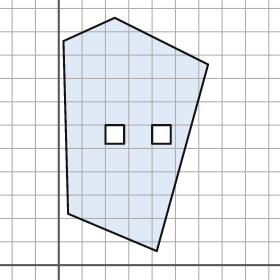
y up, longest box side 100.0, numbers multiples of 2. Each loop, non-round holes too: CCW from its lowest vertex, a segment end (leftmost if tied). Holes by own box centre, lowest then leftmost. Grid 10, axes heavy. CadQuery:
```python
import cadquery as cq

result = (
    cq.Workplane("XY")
    .moveTo(42.0, 6.0)
    .lineTo(64.0, 86.0)
    .lineTo(24.0, 106.0)
    .lineTo(2.0, 96.0)
    .lineTo(4.0, 22.0)
    .close()
    .moveTo(20.0, 52.0)
    .lineTo(28.0, 52.0)
    .lineTo(28.0, 60.0)
    .lineTo(20.0, 60.0)
    .close()
    .moveTo(40.0, 52.0)
    .lineTo(48.0, 52.0)
    .lineTo(48.0, 60.0)
    .lineTo(40.0, 60.0)
    .close()
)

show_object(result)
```